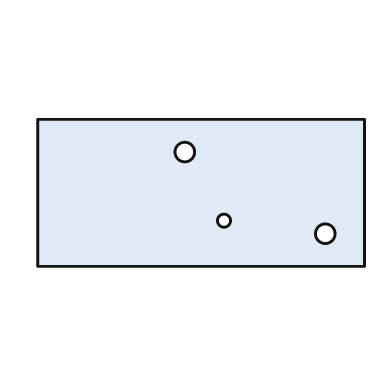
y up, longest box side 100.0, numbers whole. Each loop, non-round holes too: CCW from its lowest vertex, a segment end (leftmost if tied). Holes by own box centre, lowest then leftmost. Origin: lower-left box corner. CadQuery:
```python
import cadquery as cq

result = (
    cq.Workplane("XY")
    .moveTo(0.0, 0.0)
    .lineTo(100.0, 0.0)
    .lineTo(100.0, 45.0)
    .lineTo(0.0, 45.0)
    .close()
    .moveTo(88.0, 10.0)
    .circle(3.0)
    .moveTo(57.0, 14.0)
    .circle(2.0)
    .moveTo(45.0, 35.0)
    .circle(3.0)
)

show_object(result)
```